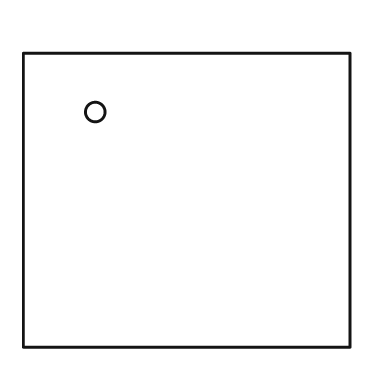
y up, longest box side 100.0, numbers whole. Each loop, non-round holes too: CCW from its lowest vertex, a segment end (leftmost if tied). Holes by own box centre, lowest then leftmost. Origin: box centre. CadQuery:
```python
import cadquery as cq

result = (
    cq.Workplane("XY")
    .moveTo(-50.0, -45.0)
    .lineTo(50.0, -45.0)
    .lineTo(50.0, 45.0)
    .lineTo(-50.0, 45.0)
    .close()
    .moveTo(-28.0, 27.0)
    .circle(3.0)
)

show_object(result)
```